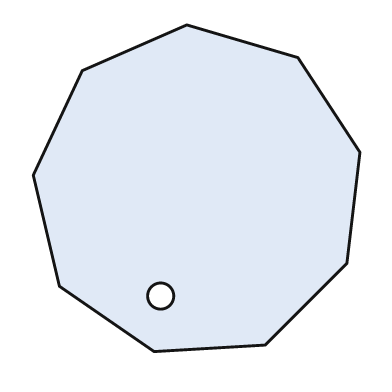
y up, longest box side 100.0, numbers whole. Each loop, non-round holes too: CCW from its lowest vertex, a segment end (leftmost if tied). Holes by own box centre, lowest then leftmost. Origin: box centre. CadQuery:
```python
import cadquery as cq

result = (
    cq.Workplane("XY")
    .moveTo(-13.0, -50.0)
    .lineTo(21.0, -48.0)
    .lineTo(46.0, -23.0)
    .lineTo(50.0, 11.0)
    .lineTo(31.0, 40.0)
    .lineTo(-3.0, 50.0)
    .lineTo(-35.0, 36.0)
    .lineTo(-50.0, 4.0)
    .lineTo(-42.0, -30.0)
    .close()
    .moveTo(-11.0, -33.0)
    .circle(4.0)
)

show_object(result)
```